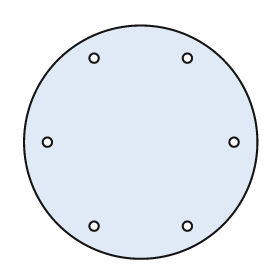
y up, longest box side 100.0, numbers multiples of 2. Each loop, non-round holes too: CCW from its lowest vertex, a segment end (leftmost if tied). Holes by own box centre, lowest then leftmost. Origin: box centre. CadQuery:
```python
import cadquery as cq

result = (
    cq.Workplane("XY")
    .moveTo(0.0, 0.0)
    .circle(50.0)
    .moveTo(-20.0, -36.0)
    .circle(2.0)
    .moveTo(20.0, -36.0)
    .circle(2.0)
    .moveTo(-40.0, 0.0)
    .circle(2.0)
    .moveTo(40.0, 0.0)
    .circle(2.0)
    .moveTo(-20.0, 36.0)
    .circle(2.0)
    .moveTo(20.0, 36.0)
    .circle(2.0)
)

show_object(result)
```